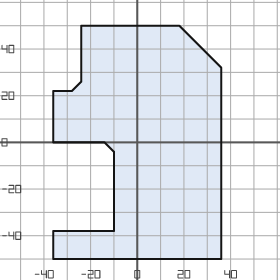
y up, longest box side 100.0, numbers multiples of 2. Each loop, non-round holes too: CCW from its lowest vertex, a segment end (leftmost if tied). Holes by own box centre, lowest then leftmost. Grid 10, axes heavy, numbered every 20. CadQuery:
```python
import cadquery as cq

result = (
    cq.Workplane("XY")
    .moveTo(-36.0, -50.0)
    .lineTo(36.0, -50.0)
    .lineTo(36.0, 32.0)
    .lineTo(18.0, 50.0)
    .lineTo(-24.0, 50.0)
    .lineTo(-24.0, 26.0)
    .lineTo(-28.0, 22.0)
    .lineTo(-36.0, 22.0)
    .lineTo(-36.0, 0.0)
    .lineTo(-14.0, 0.0)
    .lineTo(-10.0, -4.0)
    .lineTo(-10.0, -38.0)
    .lineTo(-36.0, -38.0)
    .close()
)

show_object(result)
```